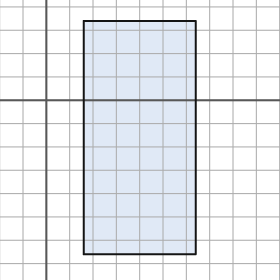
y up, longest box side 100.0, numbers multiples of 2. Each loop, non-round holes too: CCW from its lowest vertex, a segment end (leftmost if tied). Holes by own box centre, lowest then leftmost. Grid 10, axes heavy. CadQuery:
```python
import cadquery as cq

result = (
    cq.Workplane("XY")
    .moveTo(16.0, -66.0)
    .lineTo(64.0, -66.0)
    .lineTo(64.0, 34.0)
    .lineTo(16.0, 34.0)
    .close()
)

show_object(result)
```